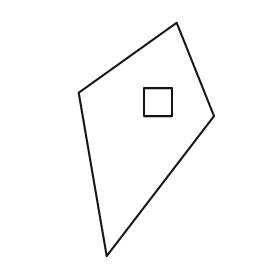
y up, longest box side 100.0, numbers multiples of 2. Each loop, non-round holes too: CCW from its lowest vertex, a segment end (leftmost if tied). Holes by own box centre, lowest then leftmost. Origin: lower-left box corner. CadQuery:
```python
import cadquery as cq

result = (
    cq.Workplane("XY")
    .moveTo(12.0, 0.0)
    .lineTo(58.0, 60.0)
    .lineTo(42.0, 100.0)
    .lineTo(0.0, 70.0)
    .close()
    .moveTo(28.0, 60.0)
    .lineTo(40.0, 60.0)
    .lineTo(40.0, 72.0)
    .lineTo(28.0, 72.0)
    .close()
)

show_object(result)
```